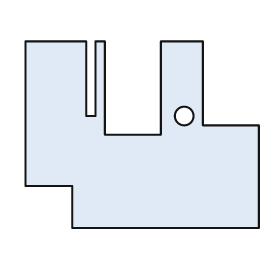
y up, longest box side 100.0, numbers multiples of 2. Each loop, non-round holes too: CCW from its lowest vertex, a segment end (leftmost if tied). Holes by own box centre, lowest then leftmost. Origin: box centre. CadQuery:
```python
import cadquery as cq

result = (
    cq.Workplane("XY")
    .moveTo(-30.0, -40.0)
    .lineTo(50.0, -40.0)
    .lineTo(50.0, 4.0)
    .lineTo(26.0, 4.0)
    .lineTo(26.0, 40.0)
    .lineTo(8.0, 40.0)
    .lineTo(8.0, 0.0)
    .lineTo(-16.0, 0.0)
    .lineTo(-16.0, 40.0)
    .lineTo(-20.0, 40.0)
    .lineTo(-20.0, 8.0)
    .lineTo(-24.0, 8.0)
    .lineTo(-24.0, 40.0)
    .lineTo(-50.0, 40.0)
    .lineTo(-50.0, -22.0)
    .lineTo(-30.0, -22.0)
    .close()
    .moveTo(18.0, 8.0)
    .circle(4.0)
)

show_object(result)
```